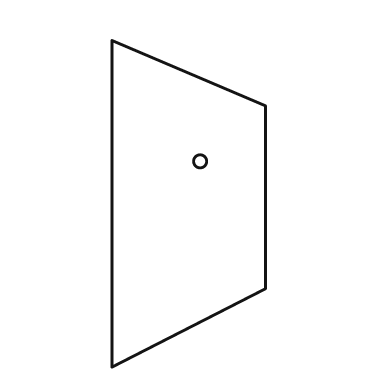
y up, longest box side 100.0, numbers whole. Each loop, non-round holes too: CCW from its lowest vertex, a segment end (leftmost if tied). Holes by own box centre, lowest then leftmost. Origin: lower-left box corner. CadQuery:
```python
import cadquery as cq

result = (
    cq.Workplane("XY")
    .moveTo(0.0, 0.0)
    .lineTo(47.0, 24.0)
    .lineTo(47.0, 80.0)
    .lineTo(0.0, 100.0)
    .close()
    .moveTo(27.0, 63.0)
    .circle(2.0)
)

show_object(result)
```